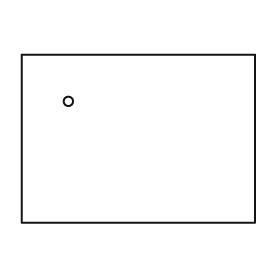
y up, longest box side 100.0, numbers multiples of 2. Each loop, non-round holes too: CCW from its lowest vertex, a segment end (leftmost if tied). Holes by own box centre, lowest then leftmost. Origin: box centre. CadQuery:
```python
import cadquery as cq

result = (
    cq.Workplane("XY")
    .moveTo(-50.0, -36.0)
    .lineTo(50.0, -36.0)
    .lineTo(50.0, 36.0)
    .lineTo(-50.0, 36.0)
    .close()
    .moveTo(-30.0, 16.0)
    .circle(2.0)
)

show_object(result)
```